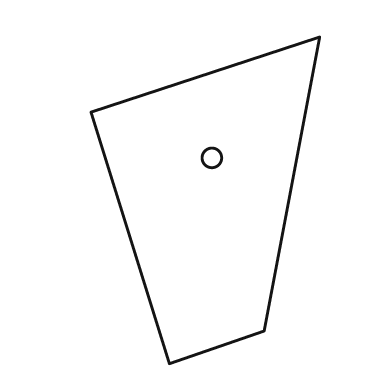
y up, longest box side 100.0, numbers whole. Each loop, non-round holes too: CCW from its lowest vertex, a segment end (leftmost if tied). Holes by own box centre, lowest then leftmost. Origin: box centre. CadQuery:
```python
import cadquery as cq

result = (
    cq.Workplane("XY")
    .moveTo(-11.0, -50.0)
    .lineTo(18.0, -40.0)
    .lineTo(35.0, 50.0)
    .lineTo(-35.0, 27.0)
    .close()
    .moveTo(2.0, 13.0)
    .circle(3.0)
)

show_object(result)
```